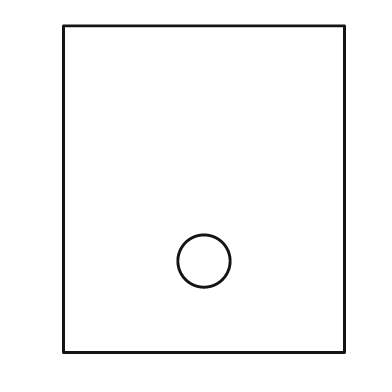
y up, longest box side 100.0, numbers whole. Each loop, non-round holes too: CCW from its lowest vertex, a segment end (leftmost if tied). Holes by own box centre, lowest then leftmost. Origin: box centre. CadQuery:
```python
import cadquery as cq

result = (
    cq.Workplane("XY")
    .moveTo(-43.0, -50.0)
    .lineTo(43.0, -50.0)
    .lineTo(43.0, 50.0)
    .lineTo(-43.0, 50.0)
    .close()
    .moveTo(0.0, -22.0)
    .circle(8.0)
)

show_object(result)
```